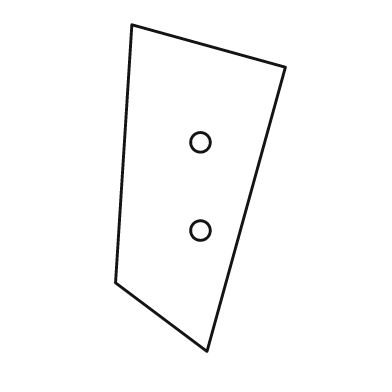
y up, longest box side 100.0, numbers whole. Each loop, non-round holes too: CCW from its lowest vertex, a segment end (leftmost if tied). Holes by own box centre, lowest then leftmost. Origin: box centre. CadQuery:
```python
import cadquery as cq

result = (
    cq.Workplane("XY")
    .moveTo(2.0, -50.0)
    .lineTo(26.0, 37.0)
    .lineTo(-21.0, 50.0)
    .lineTo(-26.0, -29.0)
    .close()
    .moveTo(0.0, -13.0)
    .circle(3.0)
    .moveTo(0.0, 14.0)
    .circle(3.0)
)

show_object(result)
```